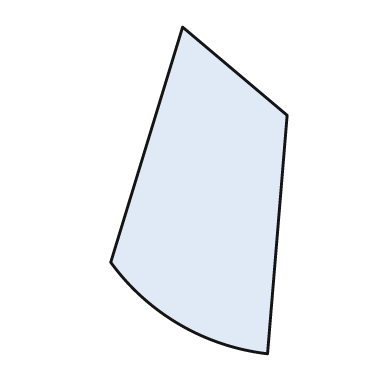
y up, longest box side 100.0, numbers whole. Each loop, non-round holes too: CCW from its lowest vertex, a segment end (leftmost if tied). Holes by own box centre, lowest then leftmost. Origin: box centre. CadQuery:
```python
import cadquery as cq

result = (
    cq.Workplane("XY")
    .moveTo(21.0, -50.0)
    .lineTo(27.0, 23.0)
    .lineTo(-5.0, 50.0)
    .lineTo(-27.0, -22.0)
    .threePointArc((-6.0, -41.0), (21.0, -50.0))
    .close()
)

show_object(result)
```